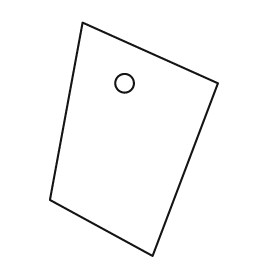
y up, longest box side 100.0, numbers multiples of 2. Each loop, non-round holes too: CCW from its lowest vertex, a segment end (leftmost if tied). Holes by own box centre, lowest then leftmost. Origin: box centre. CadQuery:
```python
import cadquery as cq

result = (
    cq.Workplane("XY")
    .moveTo(8.0, -50.0)
    .lineTo(36.0, 24.0)
    .lineTo(-22.0, 50.0)
    .lineTo(-36.0, -26.0)
    .close()
    .moveTo(-4.0, 24.0)
    .circle(4.0)
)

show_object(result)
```